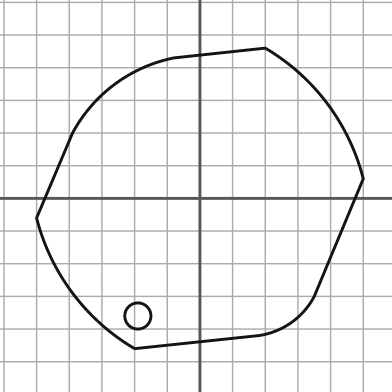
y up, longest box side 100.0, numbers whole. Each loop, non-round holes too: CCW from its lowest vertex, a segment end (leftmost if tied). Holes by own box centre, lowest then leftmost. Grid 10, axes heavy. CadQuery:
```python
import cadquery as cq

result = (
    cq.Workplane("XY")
    .moveTo(-20.0, -46.0)
    .lineTo(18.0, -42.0)
    .threePointArc((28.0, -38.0), (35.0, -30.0))
    .lineTo(50.0, 6.0)
    .threePointArc((39.0, 29.0), (20.0, 46.0))
    .lineTo(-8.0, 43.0)
    .threePointArc((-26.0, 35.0), (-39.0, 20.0))
    .lineTo(-50.0, -6.0)
    .threePointArc((-39.0, -29.0), (-20.0, -46.0))
    .close()
    .moveTo(-19.0, -36.0)
    .circle(4.0)
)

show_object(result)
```